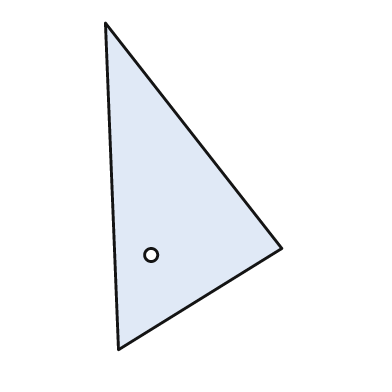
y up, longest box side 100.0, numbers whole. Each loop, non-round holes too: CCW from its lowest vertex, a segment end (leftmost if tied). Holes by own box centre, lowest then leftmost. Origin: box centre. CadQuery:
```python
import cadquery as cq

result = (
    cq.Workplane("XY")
    .moveTo(-23.0, -50.0)
    .lineTo(27.0, -19.0)
    .lineTo(-27.0, 50.0)
    .close()
    .moveTo(-13.0, -21.0)
    .circle(2.0)
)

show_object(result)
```